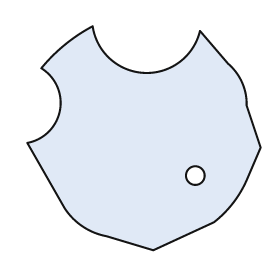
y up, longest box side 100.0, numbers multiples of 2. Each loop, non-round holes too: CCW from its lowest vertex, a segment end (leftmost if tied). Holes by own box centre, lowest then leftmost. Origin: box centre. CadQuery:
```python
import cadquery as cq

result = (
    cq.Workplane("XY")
    .moveTo(4.0, -48.0)
    .lineTo(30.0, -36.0)
    .threePointArc((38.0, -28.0), (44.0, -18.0))
    .lineTo(50.0, -4.0)
    .lineTo(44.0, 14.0)
    .threePointArc((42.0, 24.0), (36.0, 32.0))
    .lineTo(24.0, 46.0)
    .threePointArc((0.0, 28.0), (-22.0, 48.0))
    .threePointArc((-34.0, 40.0), (-44.0, 30.0))
    .threePointArc((-36.0, 12.0), (-50.0, -2.0))
    .lineTo(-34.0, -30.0)
    .threePointArc((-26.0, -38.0), (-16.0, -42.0))
    .close()
    .moveTo(22.0, -16.0)
    .circle(4.0)
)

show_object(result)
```